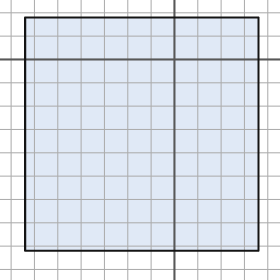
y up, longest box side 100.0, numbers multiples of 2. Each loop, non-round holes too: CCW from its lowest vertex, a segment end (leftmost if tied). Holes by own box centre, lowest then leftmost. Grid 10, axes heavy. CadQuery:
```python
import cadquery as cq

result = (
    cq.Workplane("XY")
    .moveTo(-64.0, -82.0)
    .lineTo(36.0, -82.0)
    .lineTo(36.0, 18.0)
    .lineTo(-64.0, 18.0)
    .close()
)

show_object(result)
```